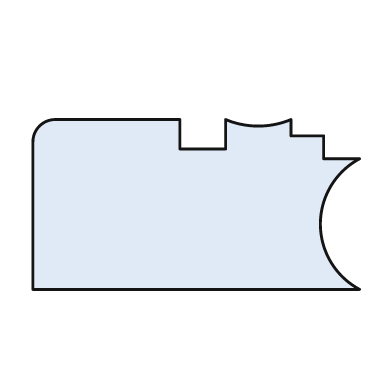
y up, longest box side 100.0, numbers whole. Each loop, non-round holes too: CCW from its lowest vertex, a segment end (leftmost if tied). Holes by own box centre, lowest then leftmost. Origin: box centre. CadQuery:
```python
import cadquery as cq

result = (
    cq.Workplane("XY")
    .moveTo(-50.0, -26.0)
    .lineTo(50.0, -26.0)
    .threePointArc((38.0, -6.0), (50.0, 14.0))
    .lineTo(39.0, 14.0)
    .lineTo(39.0, 21.0)
    .lineTo(29.0, 21.0)
    .lineTo(29.0, 26.0)
    .threePointArc((19.0, 24.0), (9.0, 26.0))
    .lineTo(9.0, 17.0)
    .lineTo(-5.0, 17.0)
    .lineTo(-5.0, 26.0)
    .lineTo(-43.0, 26.0)
    .threePointArc((-48.0, 24.0), (-50.0, 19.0))
    .close()
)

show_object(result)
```